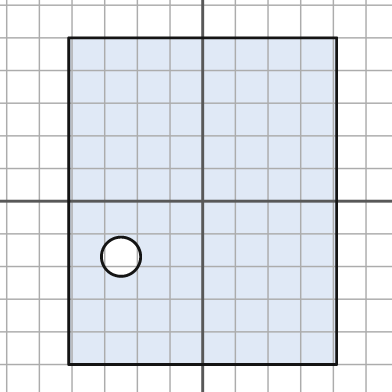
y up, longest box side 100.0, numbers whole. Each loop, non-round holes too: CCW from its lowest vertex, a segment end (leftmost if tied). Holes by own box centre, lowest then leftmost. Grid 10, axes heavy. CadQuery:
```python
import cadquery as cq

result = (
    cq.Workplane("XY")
    .moveTo(-41.0, -50.0)
    .lineTo(41.0, -50.0)
    .lineTo(41.0, 50.0)
    .lineTo(-41.0, 50.0)
    .close()
    .moveTo(-25.0, -17.0)
    .circle(6.0)
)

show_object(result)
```